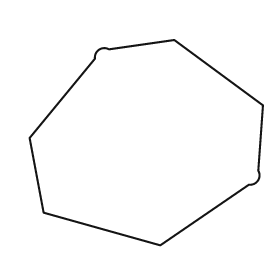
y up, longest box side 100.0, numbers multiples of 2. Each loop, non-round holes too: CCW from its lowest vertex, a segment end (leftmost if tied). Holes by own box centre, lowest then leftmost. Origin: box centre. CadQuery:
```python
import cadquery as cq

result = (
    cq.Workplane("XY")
    .moveTo(6.0, -44.0)
    .lineTo(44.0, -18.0)
    .threePointArc((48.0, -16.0), (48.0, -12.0))
    .lineTo(50.0, 16.0)
    .lineTo(12.0, 44.0)
    .lineTo(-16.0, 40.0)
    .threePointArc((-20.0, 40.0), (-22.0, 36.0))
    .lineTo(-50.0, 2.0)
    .lineTo(-44.0, -30.0)
    .close()
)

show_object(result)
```